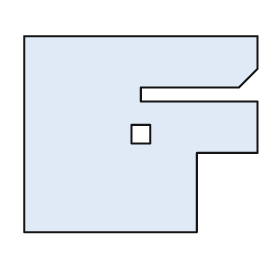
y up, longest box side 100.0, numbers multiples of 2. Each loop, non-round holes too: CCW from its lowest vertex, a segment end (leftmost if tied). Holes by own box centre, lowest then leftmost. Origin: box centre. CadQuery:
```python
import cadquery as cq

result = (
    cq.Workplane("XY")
    .moveTo(-50.0, -42.0)
    .lineTo(24.0, -42.0)
    .lineTo(24.0, -8.0)
    .lineTo(50.0, -8.0)
    .lineTo(50.0, 14.0)
    .lineTo(0.0, 14.0)
    .lineTo(0.0, 20.0)
    .lineTo(42.0, 20.0)
    .lineTo(50.0, 28.0)
    .lineTo(50.0, 42.0)
    .lineTo(-50.0, 42.0)
    .close()
    .moveTo(-4.0, -4.0)
    .lineTo(4.0, -4.0)
    .lineTo(4.0, 4.0)
    .lineTo(-4.0, 4.0)
    .close()
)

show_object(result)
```